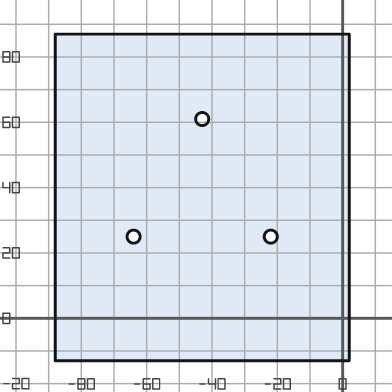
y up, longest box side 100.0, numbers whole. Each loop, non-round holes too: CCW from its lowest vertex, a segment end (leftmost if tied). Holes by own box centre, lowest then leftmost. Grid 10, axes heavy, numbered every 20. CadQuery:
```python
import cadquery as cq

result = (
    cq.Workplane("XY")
    .moveTo(-88.0, -13.0)
    .lineTo(2.0, -13.0)
    .lineTo(2.0, 87.0)
    .lineTo(-88.0, 87.0)
    .close()
    .moveTo(-64.0, 25.0)
    .circle(2.0)
    .moveTo(-22.0, 25.0)
    .circle(2.0)
    .moveTo(-43.0, 61.0)
    .circle(2.0)
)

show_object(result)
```